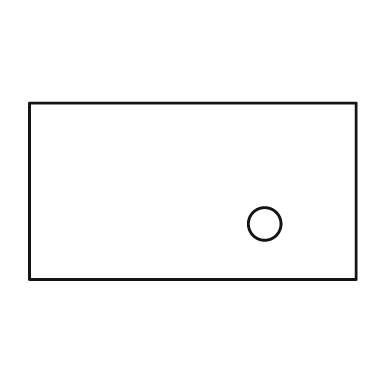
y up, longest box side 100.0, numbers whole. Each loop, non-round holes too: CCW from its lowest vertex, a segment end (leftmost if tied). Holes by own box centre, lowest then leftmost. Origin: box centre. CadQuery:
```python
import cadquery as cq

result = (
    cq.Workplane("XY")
    .moveTo(-50.0, -27.0)
    .lineTo(50.0, -27.0)
    .lineTo(50.0, 27.0)
    .lineTo(-50.0, 27.0)
    .close()
    .moveTo(22.0, -10.0)
    .circle(5.0)
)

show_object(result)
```